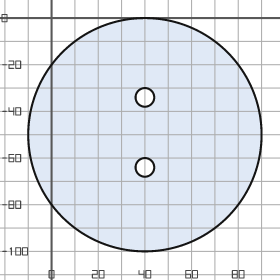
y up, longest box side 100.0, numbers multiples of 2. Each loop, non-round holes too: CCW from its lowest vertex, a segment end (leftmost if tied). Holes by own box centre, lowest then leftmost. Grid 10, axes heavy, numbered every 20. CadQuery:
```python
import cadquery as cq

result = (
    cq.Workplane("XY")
    .moveTo(40.0, -50.0)
    .circle(50.0)
    .moveTo(40.0, -64.0)
    .circle(4.0)
    .moveTo(40.0, -34.0)
    .circle(4.0)
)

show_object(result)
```